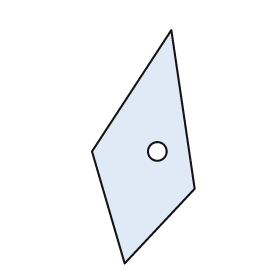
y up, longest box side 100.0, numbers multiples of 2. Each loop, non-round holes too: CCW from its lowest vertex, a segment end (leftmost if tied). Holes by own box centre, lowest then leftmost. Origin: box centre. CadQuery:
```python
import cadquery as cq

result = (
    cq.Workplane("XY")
    .moveTo(-8.0, -50.0)
    .lineTo(22.0, -18.0)
    .lineTo(12.0, 50.0)
    .lineTo(-22.0, -2.0)
    .close()
    .moveTo(6.0, -2.0)
    .circle(4.0)
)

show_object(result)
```